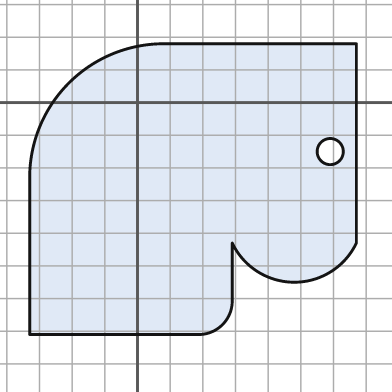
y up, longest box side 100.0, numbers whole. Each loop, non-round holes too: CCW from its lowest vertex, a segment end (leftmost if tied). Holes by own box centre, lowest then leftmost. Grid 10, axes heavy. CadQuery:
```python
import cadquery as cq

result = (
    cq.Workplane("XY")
    .moveTo(-33.0, -71.0)
    .lineTo(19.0, -71.0)
    .threePointArc((26.0, -68.0), (29.0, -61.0))
    .lineTo(29.0, -43.0)
    .threePointArc((48.0, -55.0), (67.0, -43.0))
    .lineTo(67.0, 18.0)
    .lineTo(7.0, 18.0)
    .threePointArc((-21.0, 6.0), (-33.0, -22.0))
    .close()
    .moveTo(59.0, -15.0)
    .circle(4.0)
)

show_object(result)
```